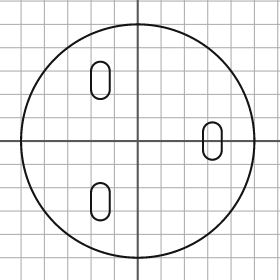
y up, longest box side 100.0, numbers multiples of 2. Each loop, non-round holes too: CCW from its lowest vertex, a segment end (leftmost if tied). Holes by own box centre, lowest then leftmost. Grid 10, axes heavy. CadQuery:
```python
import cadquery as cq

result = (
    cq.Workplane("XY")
    .moveTo(0.0, 0.0)
    .circle(50.0)
    .moveTo(-20.0, -30.0)
    .threePointArc((-16.0, -34.0), (-12.0, -30.0))
    .lineTo(-12.0, -22.0)
    .threePointArc((-16.0, -18.0), (-20.0, -22.0))
    .close()
    .moveTo(28.0, -4.0)
    .threePointArc((32.0, -8.0), (36.0, -4.0))
    .lineTo(36.0, 4.0)
    .threePointArc((32.0, 8.0), (28.0, 4.0))
    .close()
    .moveTo(-20.0, 22.0)
    .threePointArc((-16.0, 18.0), (-12.0, 22.0))
    .lineTo(-12.0, 30.0)
    .threePointArc((-16.0, 34.0), (-20.0, 30.0))
    .close()
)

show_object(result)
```